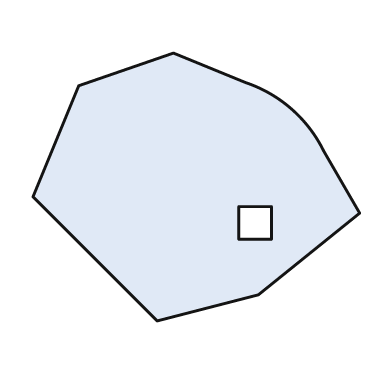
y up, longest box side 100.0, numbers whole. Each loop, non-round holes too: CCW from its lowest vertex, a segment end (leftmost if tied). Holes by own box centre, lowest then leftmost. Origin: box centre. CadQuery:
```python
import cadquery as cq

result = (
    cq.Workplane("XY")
    .moveTo(-12.0, -41.0)
    .lineTo(19.0, -33.0)
    .lineTo(50.0, -8.0)
    .lineTo(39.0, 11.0)
    .threePointArc((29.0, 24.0), (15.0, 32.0))
    .lineTo(-7.0, 41.0)
    .lineTo(-36.0, 31.0)
    .lineTo(-50.0, -3.0)
    .close()
    .moveTo(13.0, -16.0)
    .lineTo(23.0, -16.0)
    .lineTo(23.0, -6.0)
    .lineTo(13.0, -6.0)
    .close()
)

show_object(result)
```